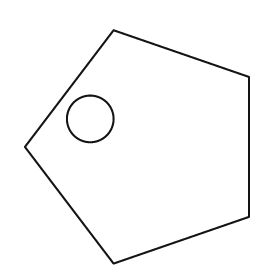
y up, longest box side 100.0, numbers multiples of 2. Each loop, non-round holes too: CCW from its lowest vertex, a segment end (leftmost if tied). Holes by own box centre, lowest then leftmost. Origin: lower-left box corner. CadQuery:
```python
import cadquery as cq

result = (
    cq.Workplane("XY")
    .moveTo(38.0, 0.0)
    .lineTo(96.0, 20.0)
    .lineTo(96.0, 80.0)
    .lineTo(38.0, 100.0)
    .lineTo(0.0, 50.0)
    .close()
    .moveTo(28.0, 62.0)
    .circle(10.0)
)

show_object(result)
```